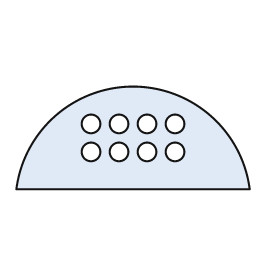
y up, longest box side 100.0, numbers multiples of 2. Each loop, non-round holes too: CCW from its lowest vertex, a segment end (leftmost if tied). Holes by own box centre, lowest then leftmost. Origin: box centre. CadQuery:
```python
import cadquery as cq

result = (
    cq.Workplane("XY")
    .moveTo(-50.0, -22.0)
    .lineTo(50.0, -22.0)
    .threePointArc((0.0, 22.0), (-50.0, -22.0))
    .close()
    .moveTo(-18.0, -6.0)
    .circle(4.0)
    .moveTo(-6.0, -6.0)
    .circle(4.0)
    .moveTo(6.0, -6.0)
    .circle(4.0)
    .moveTo(18.0, -6.0)
    .circle(4.0)
    .moveTo(-18.0, 6.0)
    .circle(4.0)
    .moveTo(-6.0, 6.0)
    .circle(4.0)
    .moveTo(6.0, 6.0)
    .circle(4.0)
    .moveTo(18.0, 6.0)
    .circle(4.0)
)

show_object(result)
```